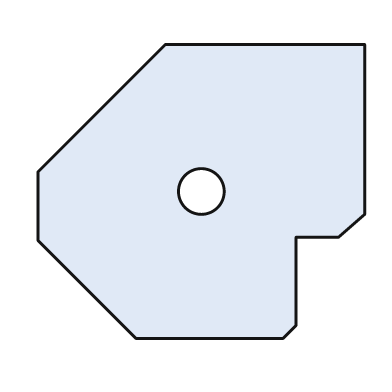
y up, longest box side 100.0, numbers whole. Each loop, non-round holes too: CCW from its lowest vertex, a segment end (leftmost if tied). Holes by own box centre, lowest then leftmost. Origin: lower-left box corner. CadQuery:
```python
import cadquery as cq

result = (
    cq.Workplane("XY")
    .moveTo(30.0, 0.0)
    .lineTo(75.0, 0.0)
    .lineTo(79.0, 4.0)
    .lineTo(79.0, 31.0)
    .lineTo(92.0, 31.0)
    .lineTo(100.0, 38.0)
    .lineTo(100.0, 90.0)
    .lineTo(39.0, 90.0)
    .lineTo(0.0, 51.0)
    .lineTo(0.0, 30.0)
    .close()
    .moveTo(50.0, 45.0)
    .circle(7.0)
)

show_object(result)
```